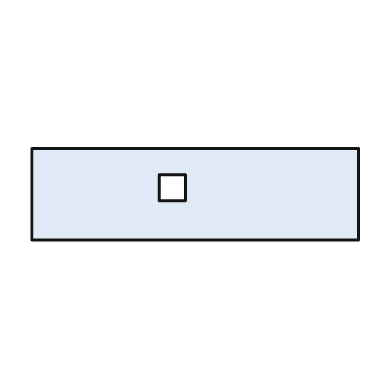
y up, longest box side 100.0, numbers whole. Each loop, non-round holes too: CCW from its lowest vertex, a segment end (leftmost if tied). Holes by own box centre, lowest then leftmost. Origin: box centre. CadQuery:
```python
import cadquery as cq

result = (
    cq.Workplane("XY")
    .moveTo(-50.0, -14.0)
    .lineTo(50.0, -14.0)
    .lineTo(50.0, 14.0)
    .lineTo(-50.0, 14.0)
    .close()
    .moveTo(-11.0, -2.0)
    .lineTo(-3.0, -2.0)
    .lineTo(-3.0, 6.0)
    .lineTo(-11.0, 6.0)
    .close()
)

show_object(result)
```